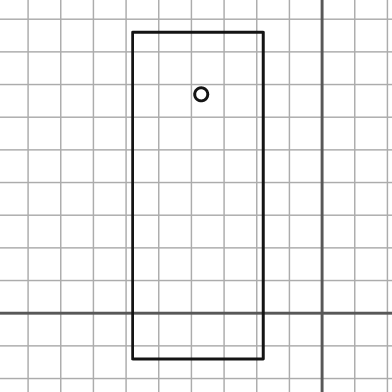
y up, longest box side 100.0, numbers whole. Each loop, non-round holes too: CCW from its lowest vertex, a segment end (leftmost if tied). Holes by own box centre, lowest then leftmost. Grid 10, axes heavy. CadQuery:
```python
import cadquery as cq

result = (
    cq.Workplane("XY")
    .moveTo(-58.0, -14.0)
    .lineTo(-18.0, -14.0)
    .lineTo(-18.0, 86.0)
    .lineTo(-58.0, 86.0)
    .close()
    .moveTo(-37.0, 67.0)
    .circle(2.0)
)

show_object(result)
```